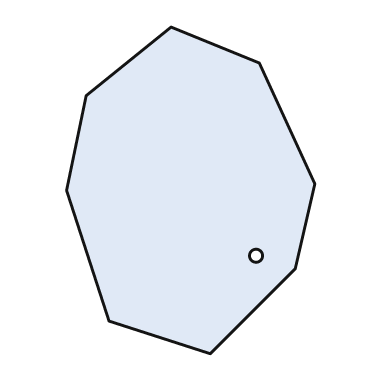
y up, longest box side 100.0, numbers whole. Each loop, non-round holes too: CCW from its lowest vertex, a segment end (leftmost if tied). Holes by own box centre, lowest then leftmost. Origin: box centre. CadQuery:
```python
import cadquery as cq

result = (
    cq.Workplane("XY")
    .moveTo(6.0, -50.0)
    .lineTo(32.0, -24.0)
    .lineTo(38.0, 2.0)
    .lineTo(21.0, 39.0)
    .lineTo(-6.0, 50.0)
    .lineTo(-32.0, 29.0)
    .lineTo(-38.0, 0.0)
    .lineTo(-25.0, -40.0)
    .close()
    .moveTo(20.0, -20.0)
    .circle(2.0)
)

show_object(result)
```